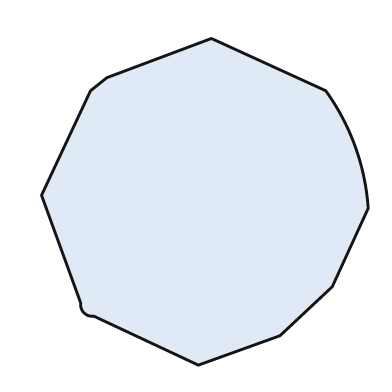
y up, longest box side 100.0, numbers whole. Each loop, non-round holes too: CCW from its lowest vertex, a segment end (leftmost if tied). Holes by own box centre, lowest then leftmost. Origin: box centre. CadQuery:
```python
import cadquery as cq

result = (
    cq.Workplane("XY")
    .moveTo(-2.0, -50.0)
    .lineTo(23.0, -41.0)
    .lineTo(39.0, -26.0)
    .lineTo(50.0, -2.0)
    .threePointArc((46.0, 17.0), (37.0, 34.0))
    .lineTo(2.0, 50.0)
    .lineTo(-30.0, 38.0)
    .lineTo(-35.0, 34.0)
    .lineTo(-50.0, 2.0)
    .lineTo(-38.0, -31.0)
    .threePointArc((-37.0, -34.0), (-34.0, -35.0))
    .close()
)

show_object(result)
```